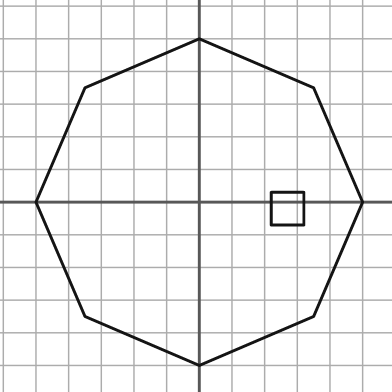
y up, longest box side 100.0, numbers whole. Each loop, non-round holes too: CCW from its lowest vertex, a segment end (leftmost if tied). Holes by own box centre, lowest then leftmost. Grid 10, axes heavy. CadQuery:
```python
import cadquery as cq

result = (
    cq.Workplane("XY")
    .moveTo(0.0, -50.0)
    .lineTo(35.0, -35.0)
    .lineTo(50.0, 0.0)
    .lineTo(35.0, 35.0)
    .lineTo(0.0, 50.0)
    .lineTo(-35.0, 35.0)
    .lineTo(-50.0, 0.0)
    .lineTo(-35.0, -35.0)
    .close()
    .moveTo(22.0, -7.0)
    .lineTo(32.0, -7.0)
    .lineTo(32.0, 3.0)
    .lineTo(22.0, 3.0)
    .close()
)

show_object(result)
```